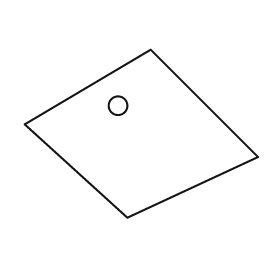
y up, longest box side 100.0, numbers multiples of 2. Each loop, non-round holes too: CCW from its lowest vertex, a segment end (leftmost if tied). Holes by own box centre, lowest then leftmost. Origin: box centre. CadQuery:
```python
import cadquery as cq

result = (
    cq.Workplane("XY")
    .moveTo(-6.0, -36.0)
    .lineTo(50.0, -10.0)
    .lineTo(4.0, 36.0)
    .lineTo(-50.0, 4.0)
    .close()
    .moveTo(-10.0, 12.0)
    .circle(4.0)
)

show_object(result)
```